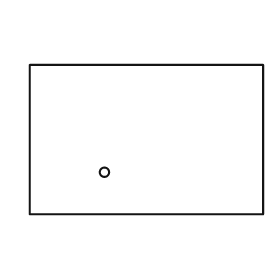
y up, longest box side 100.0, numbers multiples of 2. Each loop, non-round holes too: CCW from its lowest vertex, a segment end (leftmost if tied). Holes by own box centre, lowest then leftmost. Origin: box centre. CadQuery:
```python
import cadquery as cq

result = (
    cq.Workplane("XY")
    .moveTo(-50.0, -32.0)
    .lineTo(50.0, -32.0)
    .lineTo(50.0, 32.0)
    .lineTo(-50.0, 32.0)
    .close()
    .moveTo(-18.0, -14.0)
    .circle(2.0)
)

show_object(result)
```